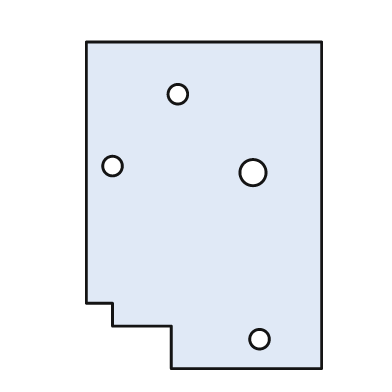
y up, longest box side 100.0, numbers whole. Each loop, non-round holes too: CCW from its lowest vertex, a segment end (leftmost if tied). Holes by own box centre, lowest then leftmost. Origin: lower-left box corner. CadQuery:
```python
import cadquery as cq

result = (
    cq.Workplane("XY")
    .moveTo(26.0, 0.0)
    .lineTo(72.0, 0.0)
    .lineTo(72.0, 100.0)
    .lineTo(0.0, 100.0)
    .lineTo(0.0, 20.0)
    .lineTo(8.0, 20.0)
    .lineTo(8.0, 13.0)
    .lineTo(26.0, 13.0)
    .close()
    .moveTo(53.0, 9.0)
    .circle(3.0)
    .moveTo(51.0, 60.0)
    .circle(4.0)
    .moveTo(8.0, 62.0)
    .circle(3.0)
    .moveTo(28.0, 84.0)
    .circle(3.0)
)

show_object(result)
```